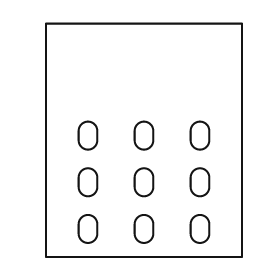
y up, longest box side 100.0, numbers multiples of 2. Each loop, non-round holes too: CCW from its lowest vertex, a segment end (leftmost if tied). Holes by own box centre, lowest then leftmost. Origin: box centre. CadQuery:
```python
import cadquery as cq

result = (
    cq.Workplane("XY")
    .moveTo(-42.0, -50.0)
    .lineTo(42.0, -50.0)
    .lineTo(42.0, 50.0)
    .lineTo(-42.0, 50.0)
    .close()
    .moveTo(-28.0, -40.0)
    .threePointArc((-24.0, -44.0), (-20.0, -40.0))
    .lineTo(-20.0, -36.0)
    .threePointArc((-24.0, -32.0), (-28.0, -36.0))
    .close()
    .moveTo(-4.0, -40.0)
    .threePointArc((0.0, -44.0), (4.0, -40.0))
    .lineTo(4.0, -36.0)
    .threePointArc((0.0, -32.0), (-4.0, -36.0))
    .close()
    .moveTo(20.0, -40.0)
    .threePointArc((24.0, -44.0), (28.0, -40.0))
    .lineTo(28.0, -36.0)
    .threePointArc((24.0, -32.0), (20.0, -36.0))
    .close()
    .moveTo(-28.0, -20.0)
    .threePointArc((-24.0, -24.0), (-20.0, -20.0))
    .lineTo(-20.0, -16.0)
    .threePointArc((-24.0, -12.0), (-28.0, -16.0))
    .close()
    .moveTo(-4.0, -20.0)
    .threePointArc((0.0, -24.0), (4.0, -20.0))
    .lineTo(4.0, -16.0)
    .threePointArc((0.0, -12.0), (-4.0, -16.0))
    .close()
    .moveTo(20.0, -20.0)
    .threePointArc((24.0, -24.0), (28.0, -20.0))
    .lineTo(28.0, -16.0)
    .threePointArc((24.0, -12.0), (20.0, -16.0))
    .close()
    .moveTo(-28.0, 0.0)
    .threePointArc((-24.0, -4.0), (-20.0, 0.0))
    .lineTo(-20.0, 4.0)
    .threePointArc((-24.0, 8.0), (-28.0, 4.0))
    .close()
    .moveTo(-4.0, 0.0)
    .threePointArc((0.0, -4.0), (4.0, 0.0))
    .lineTo(4.0, 4.0)
    .threePointArc((0.0, 8.0), (-4.0, 4.0))
    .close()
    .moveTo(20.0, 0.0)
    .threePointArc((24.0, -4.0), (28.0, 0.0))
    .lineTo(28.0, 4.0)
    .threePointArc((24.0, 8.0), (20.0, 4.0))
    .close()
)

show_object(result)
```